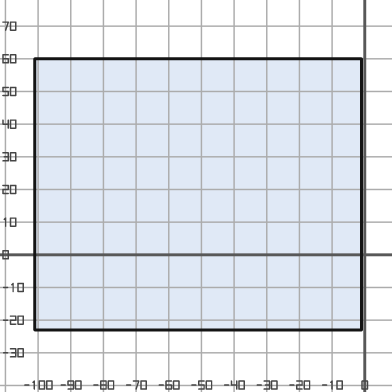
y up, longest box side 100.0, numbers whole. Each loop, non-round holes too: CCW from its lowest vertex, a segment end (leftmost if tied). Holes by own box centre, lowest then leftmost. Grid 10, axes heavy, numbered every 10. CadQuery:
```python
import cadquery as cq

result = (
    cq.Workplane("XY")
    .moveTo(-101.0, -23.0)
    .lineTo(-1.0, -23.0)
    .lineTo(-1.0, 60.0)
    .lineTo(-101.0, 60.0)
    .close()
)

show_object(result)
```